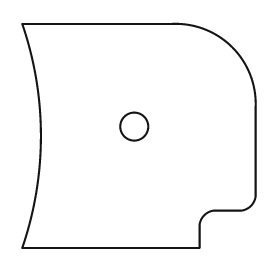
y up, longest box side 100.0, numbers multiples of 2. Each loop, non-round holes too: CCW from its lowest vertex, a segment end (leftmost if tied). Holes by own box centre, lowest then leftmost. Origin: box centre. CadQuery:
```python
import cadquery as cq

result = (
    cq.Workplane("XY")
    .moveTo(-50.0, -48.0)
    .lineTo(26.0, -48.0)
    .lineTo(26.0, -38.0)
    .threePointArc((28.0, -34.0), (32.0, -32.0))
    .lineTo(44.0, -32.0)
    .threePointArc((48.0, -30.0), (50.0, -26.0))
    .lineTo(50.0, 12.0)
    .threePointArc((40.0, 38.0), (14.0, 48.0))
    .lineTo(-50.0, 48.0)
    .threePointArc((-42.0, 0.0), (-50.0, -48.0))
    .close()
    .moveTo(-2.0, 4.0)
    .circle(6.0)
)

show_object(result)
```